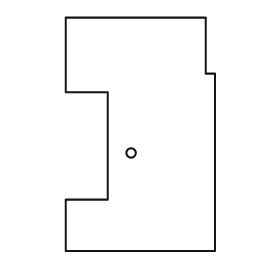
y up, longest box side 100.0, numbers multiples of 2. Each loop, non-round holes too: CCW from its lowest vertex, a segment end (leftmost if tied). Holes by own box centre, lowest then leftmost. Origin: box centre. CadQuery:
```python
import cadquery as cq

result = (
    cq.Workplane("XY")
    .moveTo(-32.0, -50.0)
    .lineTo(32.0, -50.0)
    .lineTo(32.0, 26.0)
    .lineTo(28.0, 26.0)
    .lineTo(28.0, 50.0)
    .lineTo(-32.0, 50.0)
    .lineTo(-32.0, 18.0)
    .lineTo(-14.0, 18.0)
    .lineTo(-14.0, -28.0)
    .lineTo(-32.0, -28.0)
    .close()
    .moveTo(-4.0, -8.0)
    .circle(2.0)
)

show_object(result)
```